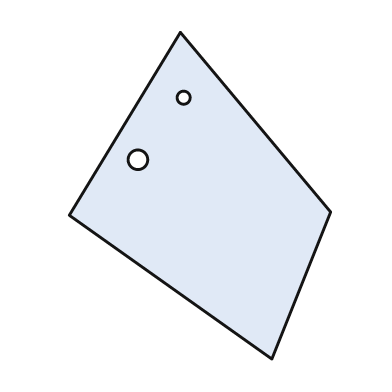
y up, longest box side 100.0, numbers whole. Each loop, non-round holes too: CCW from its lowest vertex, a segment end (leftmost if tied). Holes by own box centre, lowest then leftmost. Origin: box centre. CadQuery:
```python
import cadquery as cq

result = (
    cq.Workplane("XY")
    .moveTo(22.0, -50.0)
    .lineTo(40.0, -5.0)
    .lineTo(-6.0, 50.0)
    .lineTo(-40.0, -6.0)
    .close()
    .moveTo(-19.0, 11.0)
    .circle(3.0)
    .moveTo(-5.0, 30.0)
    .circle(2.0)
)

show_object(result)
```